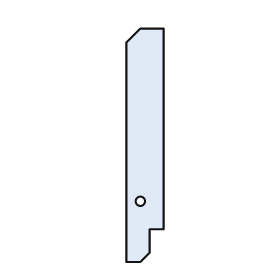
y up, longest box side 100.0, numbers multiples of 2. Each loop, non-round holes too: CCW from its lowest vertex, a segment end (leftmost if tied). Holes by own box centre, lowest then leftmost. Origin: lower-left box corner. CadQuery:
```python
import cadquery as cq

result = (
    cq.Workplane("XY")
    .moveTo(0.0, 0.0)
    .lineTo(6.0, 0.0)
    .lineTo(10.0, 4.0)
    .lineTo(10.0, 14.0)
    .lineTo(16.0, 14.0)
    .lineTo(16.0, 100.0)
    .lineTo(6.0, 100.0)
    .lineTo(0.0, 94.0)
    .close()
    .moveTo(6.0, 26.0)
    .circle(2.0)
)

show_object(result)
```